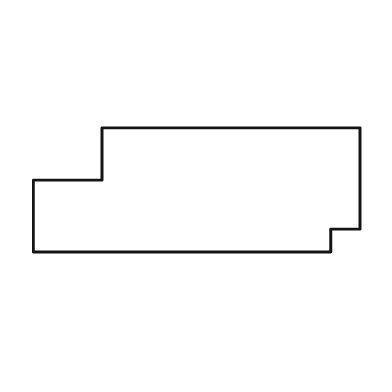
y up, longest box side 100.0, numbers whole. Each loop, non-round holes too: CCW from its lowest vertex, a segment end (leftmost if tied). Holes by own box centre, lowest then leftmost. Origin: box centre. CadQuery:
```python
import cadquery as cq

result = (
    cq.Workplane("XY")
    .moveTo(-50.0, -19.0)
    .lineTo(41.0, -19.0)
    .lineTo(41.0, -12.0)
    .lineTo(50.0, -12.0)
    .lineTo(50.0, 19.0)
    .lineTo(-29.0, 19.0)
    .lineTo(-29.0, 3.0)
    .lineTo(-50.0, 3.0)
    .close()
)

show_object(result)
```